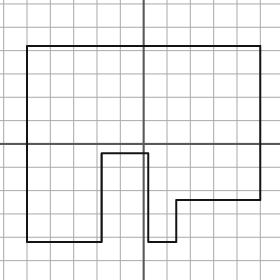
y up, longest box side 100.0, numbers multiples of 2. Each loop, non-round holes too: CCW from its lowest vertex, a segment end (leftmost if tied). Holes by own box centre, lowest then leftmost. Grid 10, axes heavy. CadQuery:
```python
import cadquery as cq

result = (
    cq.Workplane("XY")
    .moveTo(-50.0, -42.0)
    .lineTo(-18.0, -42.0)
    .lineTo(-18.0, -4.0)
    .lineTo(2.0, -4.0)
    .lineTo(2.0, -42.0)
    .lineTo(14.0, -42.0)
    .lineTo(14.0, -24.0)
    .lineTo(50.0, -24.0)
    .lineTo(50.0, 42.0)
    .lineTo(-50.0, 42.0)
    .close()
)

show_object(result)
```